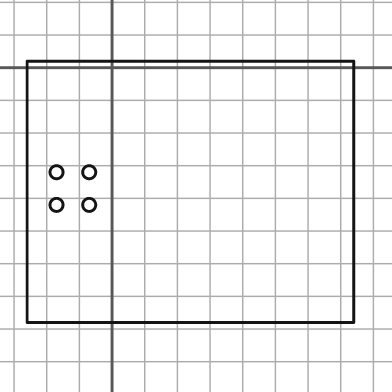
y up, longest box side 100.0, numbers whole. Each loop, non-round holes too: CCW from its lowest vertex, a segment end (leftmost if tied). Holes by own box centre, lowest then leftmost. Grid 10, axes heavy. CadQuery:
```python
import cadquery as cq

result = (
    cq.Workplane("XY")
    .moveTo(-26.0, -78.0)
    .lineTo(74.0, -78.0)
    .lineTo(74.0, 2.0)
    .lineTo(-26.0, 2.0)
    .close()
    .moveTo(-17.0, -42.0)
    .circle(2.0)
    .moveTo(-7.0, -42.0)
    .circle(2.0)
    .moveTo(-17.0, -32.0)
    .circle(2.0)
    .moveTo(-7.0, -32.0)
    .circle(2.0)
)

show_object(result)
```